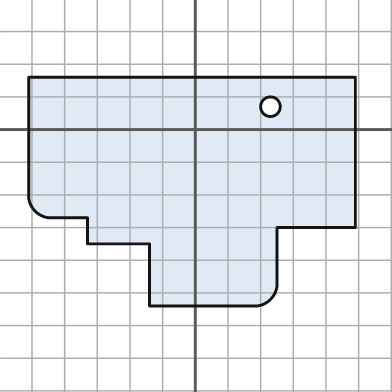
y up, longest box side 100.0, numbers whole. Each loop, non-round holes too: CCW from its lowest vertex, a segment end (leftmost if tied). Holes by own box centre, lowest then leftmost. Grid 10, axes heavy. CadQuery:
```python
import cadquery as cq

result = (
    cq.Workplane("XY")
    .moveTo(-14.0, -54.0)
    .lineTo(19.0, -54.0)
    .threePointArc((23.0, -52.0), (25.0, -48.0))
    .lineTo(25.0, -30.0)
    .lineTo(49.0, -30.0)
    .lineTo(49.0, 16.0)
    .lineTo(-51.0, 16.0)
    .lineTo(-51.0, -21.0)
    .threePointArc((-49.0, -25.0), (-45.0, -27.0))
    .lineTo(-33.0, -27.0)
    .lineTo(-33.0, -35.0)
    .lineTo(-14.0, -35.0)
    .close()
    .moveTo(23.0, 7.0)
    .circle(3.0)
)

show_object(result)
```